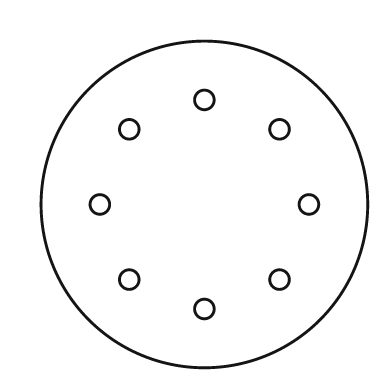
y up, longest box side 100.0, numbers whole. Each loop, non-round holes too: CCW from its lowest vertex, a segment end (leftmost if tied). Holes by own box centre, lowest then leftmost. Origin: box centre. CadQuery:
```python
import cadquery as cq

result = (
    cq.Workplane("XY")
    .moveTo(0.0, 0.0)
    .circle(50.0)
    .moveTo(0.0, -32.0)
    .circle(3.0)
    .moveTo(-23.0, -23.0)
    .circle(3.0)
    .moveTo(23.0, -23.0)
    .circle(3.0)
    .moveTo(-32.0, 0.0)
    .circle(3.0)
    .moveTo(32.0, 0.0)
    .circle(3.0)
    .moveTo(-23.0, 23.0)
    .circle(3.0)
    .moveTo(23.0, 23.0)
    .circle(3.0)
    .moveTo(0.0, 32.0)
    .circle(3.0)
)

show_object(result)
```